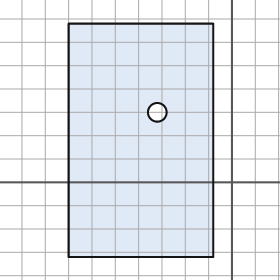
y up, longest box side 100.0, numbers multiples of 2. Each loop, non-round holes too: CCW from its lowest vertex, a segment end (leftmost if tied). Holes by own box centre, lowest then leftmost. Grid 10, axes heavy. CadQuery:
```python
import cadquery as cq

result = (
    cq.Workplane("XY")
    .moveTo(-70.0, -32.0)
    .lineTo(-8.0, -32.0)
    .lineTo(-8.0, 68.0)
    .lineTo(-70.0, 68.0)
    .close()
    .moveTo(-32.0, 30.0)
    .circle(4.0)
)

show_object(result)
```